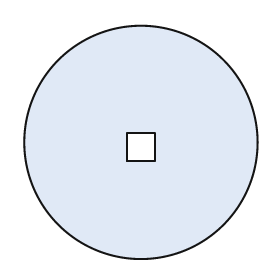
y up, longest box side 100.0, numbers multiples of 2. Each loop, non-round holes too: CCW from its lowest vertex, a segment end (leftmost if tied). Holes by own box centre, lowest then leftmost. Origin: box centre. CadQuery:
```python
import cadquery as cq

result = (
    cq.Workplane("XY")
    .moveTo(0.0, 0.0)
    .circle(50.0)
    .moveTo(-6.0, -8.0)
    .lineTo(6.0, -8.0)
    .lineTo(6.0, 4.0)
    .lineTo(-6.0, 4.0)
    .close()
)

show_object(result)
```